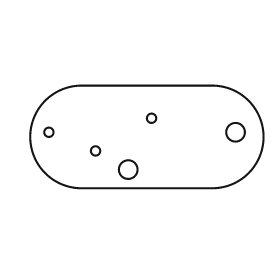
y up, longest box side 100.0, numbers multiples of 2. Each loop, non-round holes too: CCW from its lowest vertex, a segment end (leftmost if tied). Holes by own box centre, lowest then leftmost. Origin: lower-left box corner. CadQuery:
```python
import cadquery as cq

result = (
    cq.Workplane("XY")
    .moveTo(22.0, 0.0)
    .lineTo(78.0, 0.0)
    .threePointArc((100.0, 22.0), (78.0, 44.0))
    .lineTo(22.0, 44.0)
    .threePointArc((0.0, 22.0), (22.0, 0.0))
    .close()
    .moveTo(42.0, 8.0)
    .circle(4.0)
    .moveTo(28.0, 16.0)
    .circle(2.0)
    .moveTo(8.0, 24.0)
    .circle(2.0)
    .moveTo(88.0, 24.0)
    .circle(4.0)
    .moveTo(52.0, 30.0)
    .circle(2.0)
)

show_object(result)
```